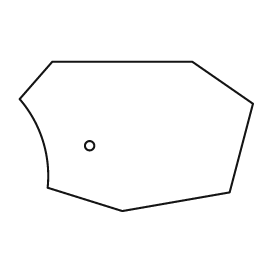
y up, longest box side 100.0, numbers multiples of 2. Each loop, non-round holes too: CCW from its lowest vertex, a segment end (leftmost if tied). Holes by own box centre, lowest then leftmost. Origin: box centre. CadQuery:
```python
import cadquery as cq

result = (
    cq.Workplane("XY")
    .moveTo(-6.0, -32.0)
    .lineTo(40.0, -24.0)
    .lineTo(50.0, 14.0)
    .lineTo(24.0, 32.0)
    .lineTo(-36.0, 32.0)
    .lineTo(-50.0, 16.0)
    .threePointArc((-40.0, -2.0), (-38.0, -22.0))
    .close()
    .moveTo(-20.0, -4.0)
    .circle(2.0)
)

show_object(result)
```